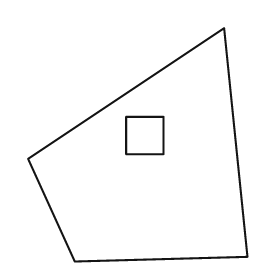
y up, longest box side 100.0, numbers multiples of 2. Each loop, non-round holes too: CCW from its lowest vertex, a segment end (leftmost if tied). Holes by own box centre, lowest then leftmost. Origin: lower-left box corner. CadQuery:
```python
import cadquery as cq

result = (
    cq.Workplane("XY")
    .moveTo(20.0, 0.0)
    .lineTo(94.0, 2.0)
    .lineTo(84.0, 100.0)
    .lineTo(0.0, 44.0)
    .close()
    .moveTo(42.0, 46.0)
    .lineTo(58.0, 46.0)
    .lineTo(58.0, 62.0)
    .lineTo(42.0, 62.0)
    .close()
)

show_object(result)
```